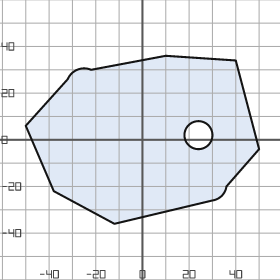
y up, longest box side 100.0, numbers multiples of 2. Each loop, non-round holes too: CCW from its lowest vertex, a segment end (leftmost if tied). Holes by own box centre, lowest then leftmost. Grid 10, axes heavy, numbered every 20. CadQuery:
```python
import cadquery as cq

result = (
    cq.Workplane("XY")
    .moveTo(-12.0, -36.0)
    .lineTo(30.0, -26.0)
    .threePointArc((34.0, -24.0), (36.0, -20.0))
    .lineTo(50.0, -4.0)
    .lineTo(40.0, 34.0)
    .lineTo(10.0, 36.0)
    .lineTo(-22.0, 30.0)
    .threePointArc((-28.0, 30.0), (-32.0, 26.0))
    .lineTo(-50.0, 6.0)
    .lineTo(-38.0, -22.0)
    .close()
    .moveTo(24.0, 2.0)
    .circle(6.0)
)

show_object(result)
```